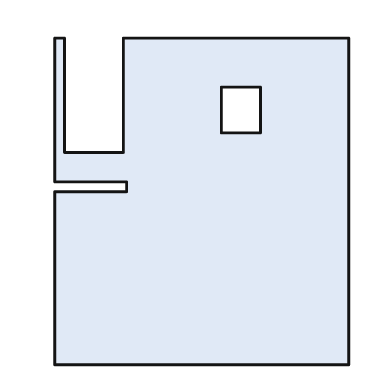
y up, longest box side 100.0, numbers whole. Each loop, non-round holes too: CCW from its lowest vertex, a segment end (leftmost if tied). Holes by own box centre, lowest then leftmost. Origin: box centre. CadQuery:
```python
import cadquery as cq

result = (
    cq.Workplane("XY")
    .moveTo(-45.0, -50.0)
    .lineTo(45.0, -50.0)
    .lineTo(45.0, 50.0)
    .lineTo(-24.0, 50.0)
    .lineTo(-24.0, 15.0)
    .lineTo(-42.0, 15.0)
    .lineTo(-42.0, 50.0)
    .lineTo(-45.0, 50.0)
    .lineTo(-45.0, 6.0)
    .lineTo(-23.0, 6.0)
    .lineTo(-23.0, 3.0)
    .lineTo(-45.0, 3.0)
    .close()
    .moveTo(6.0, 21.0)
    .lineTo(18.0, 21.0)
    .lineTo(18.0, 35.0)
    .lineTo(6.0, 35.0)
    .close()
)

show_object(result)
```